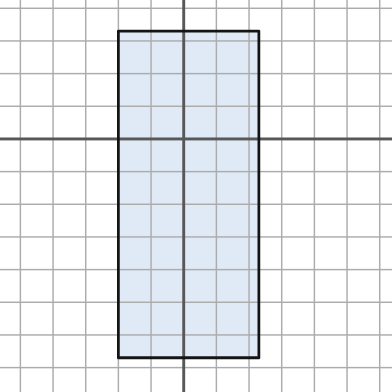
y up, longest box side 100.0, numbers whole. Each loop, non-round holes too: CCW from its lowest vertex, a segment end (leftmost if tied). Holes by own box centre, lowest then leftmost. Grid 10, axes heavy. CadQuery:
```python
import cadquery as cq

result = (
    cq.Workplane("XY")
    .moveTo(-20.0, -67.0)
    .lineTo(23.0, -67.0)
    .lineTo(23.0, 33.0)
    .lineTo(-20.0, 33.0)
    .close()
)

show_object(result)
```